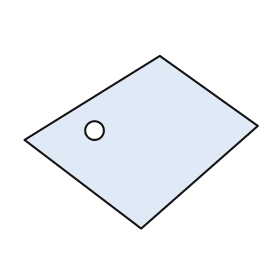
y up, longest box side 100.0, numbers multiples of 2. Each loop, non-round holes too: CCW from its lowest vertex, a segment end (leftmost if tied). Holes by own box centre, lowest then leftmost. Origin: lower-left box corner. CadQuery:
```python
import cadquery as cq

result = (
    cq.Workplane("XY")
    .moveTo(50.0, 0.0)
    .lineTo(100.0, 44.0)
    .lineTo(58.0, 74.0)
    .lineTo(0.0, 38.0)
    .close()
    .moveTo(30.0, 42.0)
    .circle(4.0)
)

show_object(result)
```